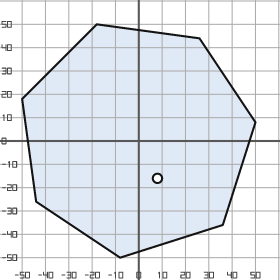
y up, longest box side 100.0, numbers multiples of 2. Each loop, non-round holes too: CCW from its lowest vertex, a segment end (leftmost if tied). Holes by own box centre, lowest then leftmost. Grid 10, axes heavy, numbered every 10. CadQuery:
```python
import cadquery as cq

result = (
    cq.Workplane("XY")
    .moveTo(-8.0, -50.0)
    .lineTo(36.0, -36.0)
    .lineTo(50.0, 8.0)
    .lineTo(26.0, 44.0)
    .lineTo(-18.0, 50.0)
    .lineTo(-50.0, 18.0)
    .lineTo(-44.0, -26.0)
    .close()
    .moveTo(8.0, -16.0)
    .circle(2.0)
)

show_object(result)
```